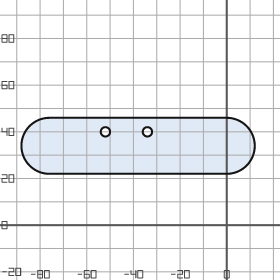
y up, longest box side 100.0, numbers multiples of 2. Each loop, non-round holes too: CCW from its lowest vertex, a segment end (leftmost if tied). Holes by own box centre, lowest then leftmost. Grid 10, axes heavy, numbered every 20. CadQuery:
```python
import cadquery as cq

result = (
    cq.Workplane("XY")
    .moveTo(-76.0, 22.0)
    .lineTo(0.0, 22.0)
    .threePointArc((12.0, 34.0), (0.0, 46.0))
    .lineTo(-76.0, 46.0)
    .threePointArc((-88.0, 34.0), (-76.0, 22.0))
    .close()
    .moveTo(-52.0, 40.0)
    .circle(2.0)
    .moveTo(-34.0, 40.0)
    .circle(2.0)
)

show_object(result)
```